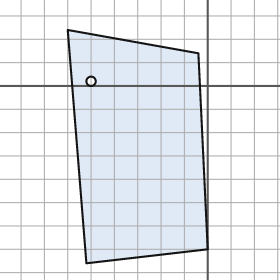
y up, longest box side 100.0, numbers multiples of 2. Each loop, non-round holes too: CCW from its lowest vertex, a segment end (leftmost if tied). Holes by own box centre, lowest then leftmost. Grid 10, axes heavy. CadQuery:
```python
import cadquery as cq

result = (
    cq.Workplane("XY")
    .moveTo(-52.0, -76.0)
    .lineTo(0.0, -70.0)
    .lineTo(-4.0, 14.0)
    .lineTo(-60.0, 24.0)
    .close()
    .moveTo(-50.0, 2.0)
    .circle(2.0)
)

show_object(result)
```